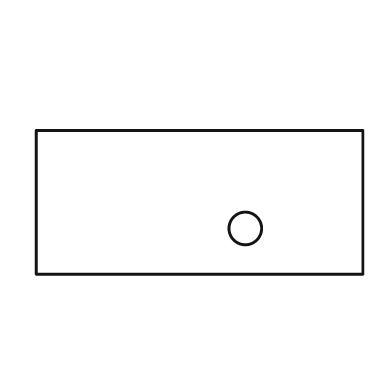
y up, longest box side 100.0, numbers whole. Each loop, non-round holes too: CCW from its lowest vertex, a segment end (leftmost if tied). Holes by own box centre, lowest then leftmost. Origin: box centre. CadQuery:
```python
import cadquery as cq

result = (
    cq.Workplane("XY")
    .moveTo(-50.0, -22.0)
    .lineTo(50.0, -22.0)
    .lineTo(50.0, 22.0)
    .lineTo(-50.0, 22.0)
    .close()
    .moveTo(14.0, -8.0)
    .circle(5.0)
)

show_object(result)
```